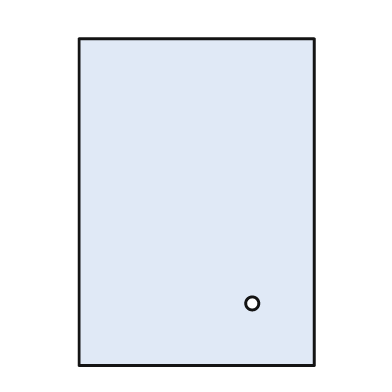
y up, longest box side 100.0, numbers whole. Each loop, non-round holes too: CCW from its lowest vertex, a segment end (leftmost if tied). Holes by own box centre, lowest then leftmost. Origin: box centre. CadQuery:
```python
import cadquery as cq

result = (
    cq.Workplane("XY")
    .moveTo(-36.0, -50.0)
    .lineTo(36.0, -50.0)
    .lineTo(36.0, 50.0)
    .lineTo(-36.0, 50.0)
    .close()
    .moveTo(17.0, -31.0)
    .circle(2.0)
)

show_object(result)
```